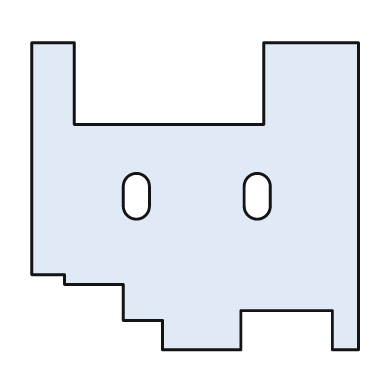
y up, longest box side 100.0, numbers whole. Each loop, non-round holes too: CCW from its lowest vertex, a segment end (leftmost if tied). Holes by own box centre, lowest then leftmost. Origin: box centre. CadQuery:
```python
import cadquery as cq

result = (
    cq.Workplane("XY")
    .moveTo(-10.0, -47.0)
    .lineTo(14.0, -47.0)
    .lineTo(14.0, -35.0)
    .lineTo(42.0, -35.0)
    .lineTo(42.0, -47.0)
    .lineTo(50.0, -47.0)
    .lineTo(50.0, 47.0)
    .lineTo(21.0, 47.0)
    .lineTo(21.0, 22.0)
    .lineTo(-37.0, 22.0)
    .lineTo(-37.0, 47.0)
    .lineTo(-50.0, 47.0)
    .lineTo(-50.0, -24.0)
    .lineTo(-40.0, -24.0)
    .lineTo(-40.0, -27.0)
    .lineTo(-22.0, -27.0)
    .lineTo(-22.0, -38.0)
    .lineTo(-10.0, -38.0)
    .close()
    .moveTo(-22.0, -3.0)
    .threePointArc((-18.0, -7.0), (-14.0, -3.0))
    .lineTo(-14.0, 3.0)
    .threePointArc((-18.0, 7.0), (-22.0, 3.0))
    .close()
    .moveTo(15.0, -3.0)
    .threePointArc((19.0, -7.0), (23.0, -3.0))
    .lineTo(23.0, 3.0)
    .threePointArc((19.0, 7.0), (15.0, 3.0))
    .close()
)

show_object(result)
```